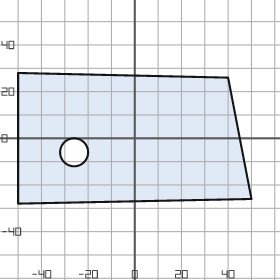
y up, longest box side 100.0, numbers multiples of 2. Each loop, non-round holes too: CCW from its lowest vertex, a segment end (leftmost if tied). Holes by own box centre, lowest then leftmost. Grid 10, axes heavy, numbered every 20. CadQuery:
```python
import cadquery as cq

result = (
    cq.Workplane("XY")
    .moveTo(-50.0, -28.0)
    .lineTo(50.0, -26.0)
    .lineTo(40.0, 26.0)
    .lineTo(-50.0, 28.0)
    .close()
    .moveTo(-26.0, -6.0)
    .circle(6.0)
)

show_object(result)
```